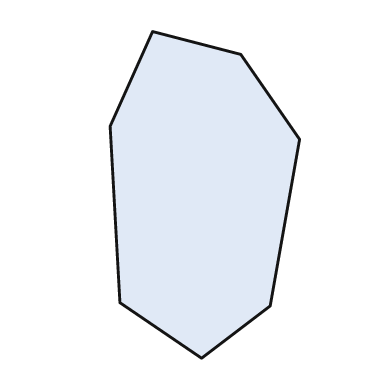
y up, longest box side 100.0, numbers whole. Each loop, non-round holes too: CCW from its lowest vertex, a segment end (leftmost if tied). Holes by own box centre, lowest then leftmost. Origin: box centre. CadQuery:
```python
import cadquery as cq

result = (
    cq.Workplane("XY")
    .moveTo(-1.0, -50.0)
    .lineTo(20.0, -34.0)
    .lineTo(29.0, 17.0)
    .lineTo(11.0, 43.0)
    .lineTo(-16.0, 50.0)
    .lineTo(-29.0, 21.0)
    .lineTo(-26.0, -33.0)
    .close()
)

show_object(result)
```